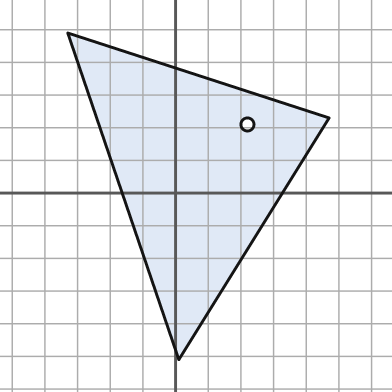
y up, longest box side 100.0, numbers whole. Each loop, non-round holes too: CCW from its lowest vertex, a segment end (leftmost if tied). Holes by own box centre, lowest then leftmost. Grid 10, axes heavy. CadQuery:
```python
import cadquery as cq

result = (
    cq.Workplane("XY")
    .moveTo(1.0, -51.0)
    .lineTo(47.0, 23.0)
    .lineTo(-33.0, 49.0)
    .close()
    .moveTo(22.0, 21.0)
    .circle(2.0)
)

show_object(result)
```